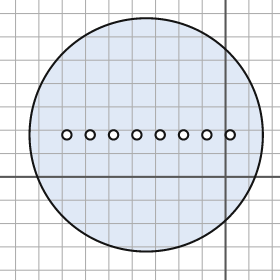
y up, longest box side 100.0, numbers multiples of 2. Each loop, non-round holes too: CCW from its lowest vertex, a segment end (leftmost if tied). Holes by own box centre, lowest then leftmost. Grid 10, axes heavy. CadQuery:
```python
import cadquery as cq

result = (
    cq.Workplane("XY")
    .moveTo(-34.0, 18.0)
    .circle(50.0)
    .moveTo(-68.0, 18.0)
    .circle(2.0)
    .moveTo(-58.0, 18.0)
    .circle(2.0)
    .moveTo(-48.0, 18.0)
    .circle(2.0)
    .moveTo(-38.0, 18.0)
    .circle(2.0)
    .moveTo(-28.0, 18.0)
    .circle(2.0)
    .moveTo(-18.0, 18.0)
    .circle(2.0)
    .moveTo(-8.0, 18.0)
    .circle(2.0)
    .moveTo(2.0, 18.0)
    .circle(2.0)
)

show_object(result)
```